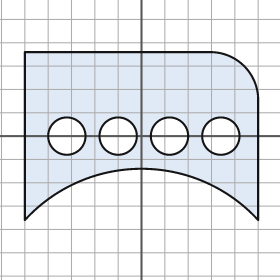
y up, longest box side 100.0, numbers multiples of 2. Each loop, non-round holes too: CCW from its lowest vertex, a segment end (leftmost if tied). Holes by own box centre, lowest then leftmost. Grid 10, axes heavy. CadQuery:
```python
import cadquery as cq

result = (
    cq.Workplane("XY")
    .moveTo(-50.0, -36.0)
    .threePointArc((0.0, -14.0), (50.0, -36.0))
    .lineTo(50.0, 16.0)
    .threePointArc((44.0, 30.0), (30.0, 36.0))
    .lineTo(-50.0, 36.0)
    .close()
    .moveTo(-32.0, 0.0)
    .circle(8.0)
    .moveTo(-10.0, 0.0)
    .circle(8.0)
    .moveTo(12.0, 0.0)
    .circle(8.0)
    .moveTo(34.0, 0.0)
    .circle(8.0)
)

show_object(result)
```